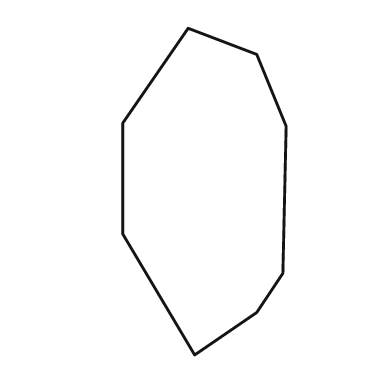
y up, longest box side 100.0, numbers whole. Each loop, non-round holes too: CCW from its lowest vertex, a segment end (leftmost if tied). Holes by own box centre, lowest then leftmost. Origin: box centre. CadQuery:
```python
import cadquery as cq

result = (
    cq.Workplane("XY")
    .moveTo(-3.0, -50.0)
    .lineTo(16.0, -37.0)
    .lineTo(24.0, -25.0)
    .lineTo(25.0, 20.0)
    .lineTo(16.0, 42.0)
    .lineTo(-5.0, 50.0)
    .lineTo(-25.0, 21.0)
    .lineTo(-25.0, -13.0)
    .close()
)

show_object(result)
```